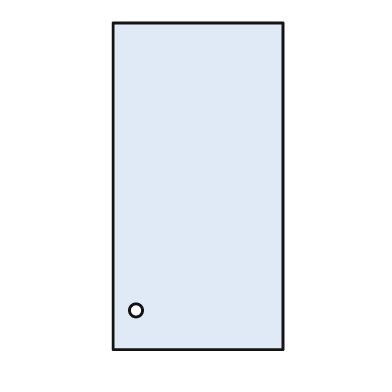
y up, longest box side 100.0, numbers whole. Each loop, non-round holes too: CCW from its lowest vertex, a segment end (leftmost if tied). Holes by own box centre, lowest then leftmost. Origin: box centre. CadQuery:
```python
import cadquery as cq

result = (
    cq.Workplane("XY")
    .moveTo(-26.0, -50.0)
    .lineTo(26.0, -50.0)
    .lineTo(26.0, 50.0)
    .lineTo(-26.0, 50.0)
    .close()
    .moveTo(-19.0, -38.0)
    .circle(2.0)
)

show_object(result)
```